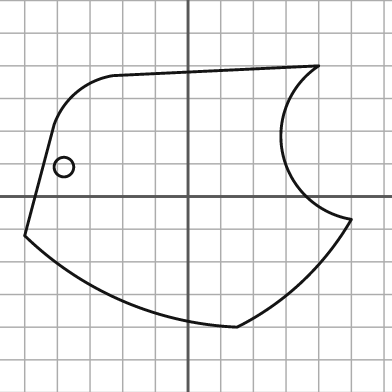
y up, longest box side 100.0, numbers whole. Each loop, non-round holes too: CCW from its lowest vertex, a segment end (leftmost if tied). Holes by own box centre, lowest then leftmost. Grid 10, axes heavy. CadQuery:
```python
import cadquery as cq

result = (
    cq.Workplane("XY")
    .moveTo(15.0, -40.0)
    .threePointArc((35.0, -26.0), (50.0, -7.0))
    .threePointArc((29.0, 13.0), (40.0, 40.0))
    .lineTo(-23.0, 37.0)
    .threePointArc((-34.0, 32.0), (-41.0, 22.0))
    .lineTo(-50.0, -12.0)
    .threePointArc((-20.0, -32.0), (15.0, -40.0))
    .close()
    .moveTo(-38.0, 9.0)
    .circle(3.0)
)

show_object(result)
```